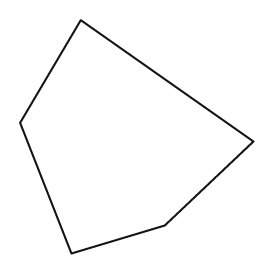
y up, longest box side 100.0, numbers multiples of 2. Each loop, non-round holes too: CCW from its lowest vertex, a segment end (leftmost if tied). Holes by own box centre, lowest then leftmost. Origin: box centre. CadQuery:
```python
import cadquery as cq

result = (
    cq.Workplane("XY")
    .moveTo(-28.0, -50.0)
    .lineTo(12.0, -38.0)
    .lineTo(50.0, -2.0)
    .lineTo(-24.0, 50.0)
    .lineTo(-50.0, 6.0)
    .close()
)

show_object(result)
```